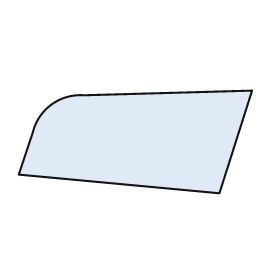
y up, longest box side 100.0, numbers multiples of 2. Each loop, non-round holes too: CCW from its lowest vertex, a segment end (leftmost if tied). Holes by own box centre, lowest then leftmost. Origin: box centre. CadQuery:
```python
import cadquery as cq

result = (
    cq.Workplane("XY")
    .moveTo(36.0, -22.0)
    .lineTo(50.0, 22.0)
    .lineTo(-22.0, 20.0)
    .threePointArc((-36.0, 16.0), (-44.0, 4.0))
    .lineTo(-50.0, -14.0)
    .close()
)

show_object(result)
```